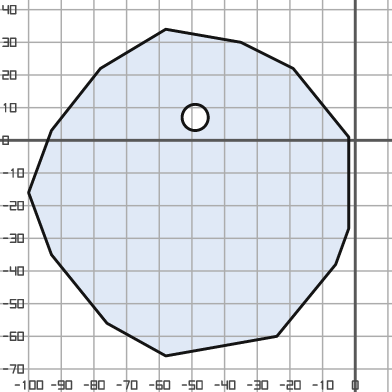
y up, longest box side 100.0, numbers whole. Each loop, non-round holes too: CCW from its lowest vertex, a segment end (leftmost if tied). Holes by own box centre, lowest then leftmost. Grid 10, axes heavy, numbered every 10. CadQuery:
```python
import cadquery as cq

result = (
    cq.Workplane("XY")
    .moveTo(-58.0, -66.0)
    .lineTo(-24.0, -60.0)
    .lineTo(-6.0, -38.0)
    .lineTo(-2.0, -27.0)
    .lineTo(-2.0, 1.0)
    .lineTo(-19.0, 22.0)
    .lineTo(-35.0, 30.0)
    .lineTo(-58.0, 34.0)
    .lineTo(-78.0, 22.0)
    .lineTo(-93.0, 3.0)
    .lineTo(-100.0, -16.0)
    .lineTo(-93.0, -35.0)
    .lineTo(-76.0, -56.0)
    .close()
    .moveTo(-49.0, 7.0)
    .circle(4.0)
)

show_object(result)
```